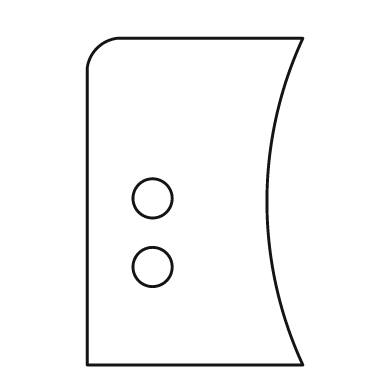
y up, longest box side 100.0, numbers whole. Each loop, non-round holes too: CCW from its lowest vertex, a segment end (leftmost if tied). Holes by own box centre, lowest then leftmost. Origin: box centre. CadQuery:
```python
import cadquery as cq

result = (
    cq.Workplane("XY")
    .moveTo(-33.0, -50.0)
    .lineTo(33.0, -50.0)
    .threePointArc((22.0, 0.0), (33.0, 50.0))
    .lineTo(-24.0, 50.0)
    .threePointArc((-30.0, 47.0), (-33.0, 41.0))
    .close()
    .moveTo(-13.0, -20.0)
    .circle(6.0)
    .moveTo(-13.0, 1.0)
    .circle(6.0)
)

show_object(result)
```